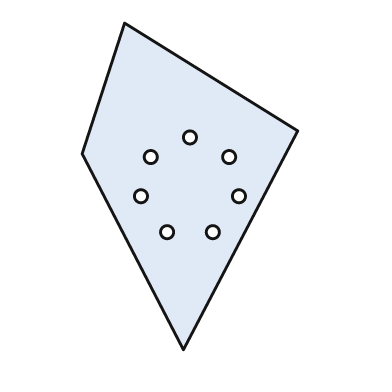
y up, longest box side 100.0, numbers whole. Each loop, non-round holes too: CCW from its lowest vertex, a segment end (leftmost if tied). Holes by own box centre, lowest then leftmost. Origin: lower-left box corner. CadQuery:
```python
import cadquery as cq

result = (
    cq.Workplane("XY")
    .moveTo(31.0, 0.0)
    .lineTo(66.0, 67.0)
    .lineTo(13.0, 100.0)
    .lineTo(0.0, 60.0)
    .close()
    .moveTo(26.0, 36.0)
    .circle(2.0)
    .moveTo(40.0, 36.0)
    .circle(2.0)
    .moveTo(18.0, 47.0)
    .circle(2.0)
    .moveTo(48.0, 47.0)
    .circle(2.0)
    .moveTo(21.0, 59.0)
    .circle(2.0)
    .moveTo(45.0, 59.0)
    .circle(2.0)
    .moveTo(33.0, 65.0)
    .circle(2.0)
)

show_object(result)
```